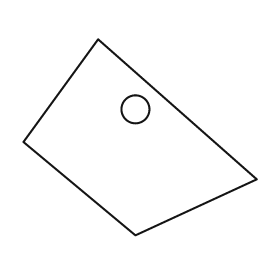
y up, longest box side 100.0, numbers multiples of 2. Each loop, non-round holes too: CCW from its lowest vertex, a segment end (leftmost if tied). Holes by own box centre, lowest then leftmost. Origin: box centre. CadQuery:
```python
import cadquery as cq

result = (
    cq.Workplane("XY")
    .moveTo(-2.0, -42.0)
    .lineTo(50.0, -18.0)
    .lineTo(-18.0, 42.0)
    .lineTo(-50.0, -2.0)
    .close()
    .moveTo(-2.0, 12.0)
    .circle(6.0)
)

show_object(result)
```